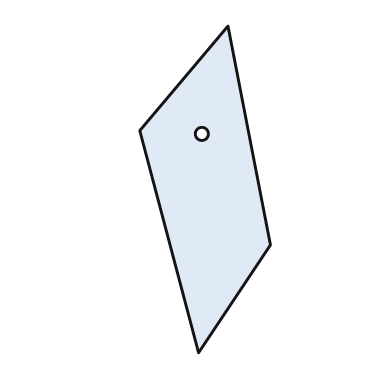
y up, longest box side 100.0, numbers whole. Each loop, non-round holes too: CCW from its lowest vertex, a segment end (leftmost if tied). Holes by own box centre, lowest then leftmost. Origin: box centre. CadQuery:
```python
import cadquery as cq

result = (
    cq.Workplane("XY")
    .moveTo(-2.0, -50.0)
    .lineTo(20.0, -17.0)
    .lineTo(7.0, 50.0)
    .lineTo(-20.0, 18.0)
    .close()
    .moveTo(-1.0, 17.0)
    .circle(2.0)
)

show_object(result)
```